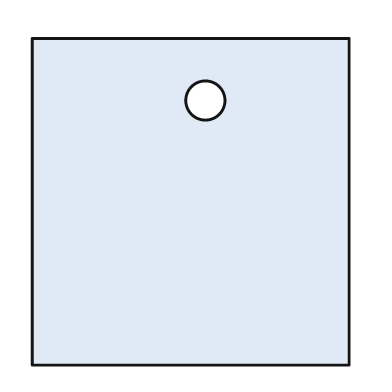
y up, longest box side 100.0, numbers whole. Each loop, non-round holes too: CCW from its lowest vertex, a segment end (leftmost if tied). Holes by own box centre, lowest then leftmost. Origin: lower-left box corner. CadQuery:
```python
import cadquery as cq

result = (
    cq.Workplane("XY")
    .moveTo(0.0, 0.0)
    .lineTo(97.0, 0.0)
    .lineTo(97.0, 100.0)
    .lineTo(0.0, 100.0)
    .close()
    .moveTo(53.0, 81.0)
    .circle(6.0)
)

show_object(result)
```